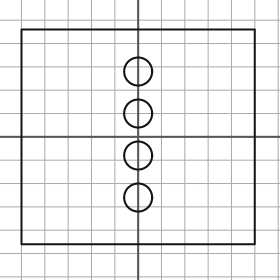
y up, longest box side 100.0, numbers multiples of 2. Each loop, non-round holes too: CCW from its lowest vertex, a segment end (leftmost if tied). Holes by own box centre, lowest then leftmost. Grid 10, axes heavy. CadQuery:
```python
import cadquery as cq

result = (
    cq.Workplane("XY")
    .moveTo(-50.0, -46.0)
    .lineTo(50.0, -46.0)
    .lineTo(50.0, 46.0)
    .lineTo(-50.0, 46.0)
    .close()
    .moveTo(0.0, -26.0)
    .circle(6.0)
    .moveTo(0.0, -8.0)
    .circle(6.0)
    .moveTo(0.0, 10.0)
    .circle(6.0)
    .moveTo(0.0, 28.0)
    .circle(6.0)
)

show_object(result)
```